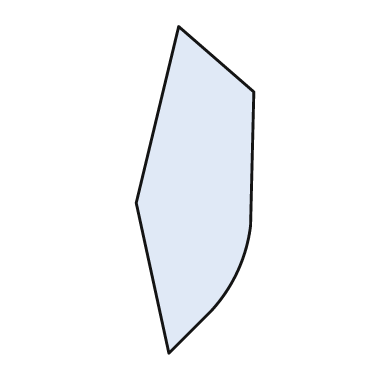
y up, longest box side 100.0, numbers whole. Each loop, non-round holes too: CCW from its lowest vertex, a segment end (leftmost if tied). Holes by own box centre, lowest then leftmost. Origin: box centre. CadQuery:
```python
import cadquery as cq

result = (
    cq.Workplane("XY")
    .moveTo(-8.0, -50.0)
    .lineTo(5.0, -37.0)
    .threePointArc((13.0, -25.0), (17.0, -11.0))
    .lineTo(18.0, 30.0)
    .lineTo(-5.0, 50.0)
    .lineTo(-18.0, -4.0)
    .close()
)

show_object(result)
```